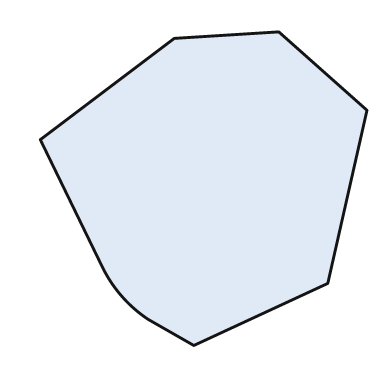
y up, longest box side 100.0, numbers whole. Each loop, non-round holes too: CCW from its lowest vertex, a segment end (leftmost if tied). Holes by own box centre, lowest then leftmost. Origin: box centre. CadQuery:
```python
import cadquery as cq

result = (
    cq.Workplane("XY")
    .moveTo(-3.0, -48.0)
    .lineTo(38.0, -29.0)
    .lineTo(50.0, 24.0)
    .lineTo(23.0, 48.0)
    .lineTo(-9.0, 46.0)
    .lineTo(-50.0, 15.0)
    .lineTo(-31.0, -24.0)
    .threePointArc((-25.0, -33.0), (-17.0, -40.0))
    .close()
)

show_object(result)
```